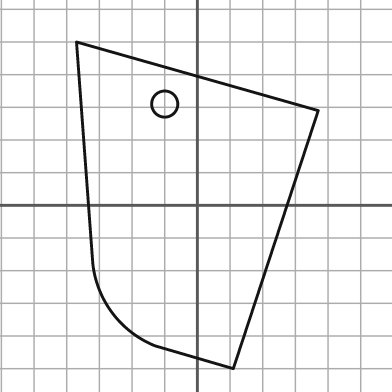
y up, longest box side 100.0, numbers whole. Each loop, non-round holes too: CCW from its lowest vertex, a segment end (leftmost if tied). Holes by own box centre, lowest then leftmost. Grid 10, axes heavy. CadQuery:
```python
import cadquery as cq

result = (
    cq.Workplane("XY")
    .moveTo(11.0, -50.0)
    .lineTo(37.0, 29.0)
    .lineTo(-37.0, 50.0)
    .lineTo(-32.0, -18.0)
    .threePointArc((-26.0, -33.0), (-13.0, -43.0))
    .close()
    .moveTo(-10.0, 31.0)
    .circle(4.0)
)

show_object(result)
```